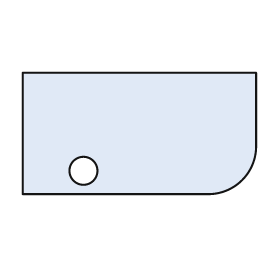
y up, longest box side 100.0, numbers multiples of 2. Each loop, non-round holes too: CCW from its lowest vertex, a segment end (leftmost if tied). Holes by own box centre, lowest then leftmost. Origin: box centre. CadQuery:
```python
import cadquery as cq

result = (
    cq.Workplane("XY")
    .moveTo(-50.0, -26.0)
    .lineTo(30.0, -26.0)
    .threePointArc((44.0, -20.0), (50.0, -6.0))
    .lineTo(50.0, 26.0)
    .lineTo(-50.0, 26.0)
    .close()
    .moveTo(-24.0, -16.0)
    .circle(6.0)
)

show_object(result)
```